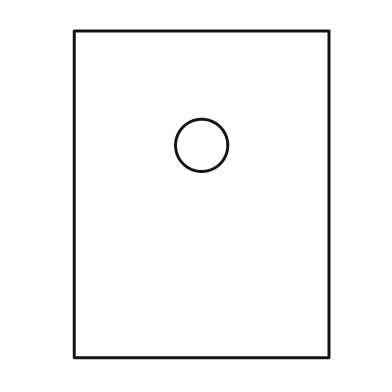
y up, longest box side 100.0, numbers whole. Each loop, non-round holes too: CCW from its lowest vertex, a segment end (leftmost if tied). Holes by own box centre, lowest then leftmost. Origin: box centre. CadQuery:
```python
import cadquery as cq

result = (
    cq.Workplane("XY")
    .moveTo(-39.0, -50.0)
    .lineTo(39.0, -50.0)
    .lineTo(39.0, 50.0)
    .lineTo(-39.0, 50.0)
    .close()
    .moveTo(0.0, 15.0)
    .circle(8.0)
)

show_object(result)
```